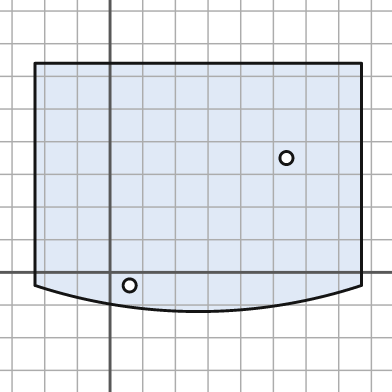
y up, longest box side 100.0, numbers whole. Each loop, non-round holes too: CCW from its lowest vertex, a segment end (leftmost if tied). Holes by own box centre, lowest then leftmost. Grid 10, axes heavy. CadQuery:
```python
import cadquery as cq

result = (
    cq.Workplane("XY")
    .moveTo(-23.0, -4.0)
    .threePointArc((27.0, -12.0), (77.0, -4.0))
    .lineTo(77.0, 64.0)
    .lineTo(-23.0, 64.0)
    .close()
    .moveTo(6.0, -4.0)
    .circle(2.0)
    .moveTo(54.0, 35.0)
    .circle(2.0)
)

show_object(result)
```